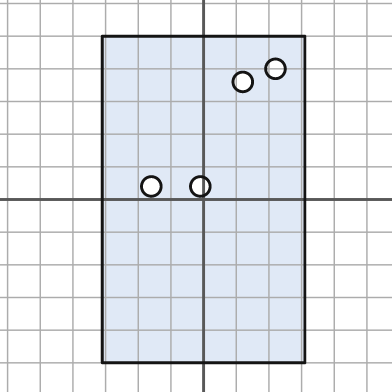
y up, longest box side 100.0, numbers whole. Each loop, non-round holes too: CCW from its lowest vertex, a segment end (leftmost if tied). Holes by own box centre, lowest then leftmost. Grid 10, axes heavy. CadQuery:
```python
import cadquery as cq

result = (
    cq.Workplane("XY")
    .moveTo(-31.0, -50.0)
    .lineTo(31.0, -50.0)
    .lineTo(31.0, 50.0)
    .lineTo(-31.0, 50.0)
    .close()
    .moveTo(-16.0, 4.0)
    .circle(3.0)
    .moveTo(-1.0, 4.0)
    .circle(3.0)
    .moveTo(12.0, 36.0)
    .circle(3.0)
    .moveTo(22.0, 40.0)
    .circle(3.0)
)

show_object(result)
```